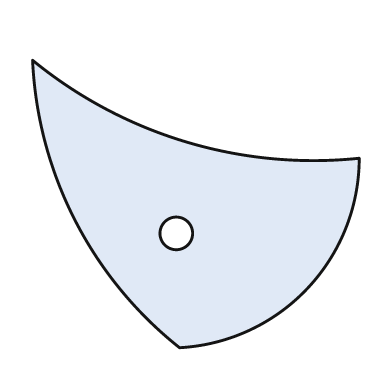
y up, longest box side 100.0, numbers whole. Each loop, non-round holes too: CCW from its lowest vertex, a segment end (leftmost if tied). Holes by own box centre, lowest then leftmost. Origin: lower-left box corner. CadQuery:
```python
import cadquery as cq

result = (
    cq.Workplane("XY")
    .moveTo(45.0, 0.0)
    .threePointArc((84.0, 18.0), (100.0, 58.0))
    .threePointArc((47.0, 63.0), (0.0, 88.0))
    .threePointArc((13.0, 39.0), (45.0, 0.0))
    .close()
    .moveTo(44.0, 35.0)
    .circle(5.0)
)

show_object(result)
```